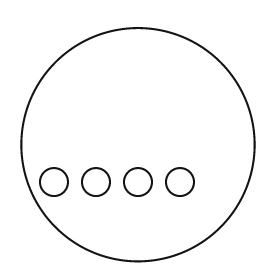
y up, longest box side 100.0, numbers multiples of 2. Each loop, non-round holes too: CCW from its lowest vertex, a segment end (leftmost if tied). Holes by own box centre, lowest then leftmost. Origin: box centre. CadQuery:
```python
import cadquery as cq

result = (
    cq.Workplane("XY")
    .moveTo(0.0, 0.0)
    .circle(50.0)
    .moveTo(-36.0, -16.0)
    .circle(6.0)
    .moveTo(-18.0, -16.0)
    .circle(6.0)
    .moveTo(0.0, -16.0)
    .circle(6.0)
    .moveTo(18.0, -16.0)
    .circle(6.0)
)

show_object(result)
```